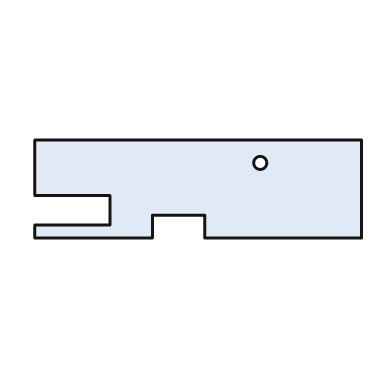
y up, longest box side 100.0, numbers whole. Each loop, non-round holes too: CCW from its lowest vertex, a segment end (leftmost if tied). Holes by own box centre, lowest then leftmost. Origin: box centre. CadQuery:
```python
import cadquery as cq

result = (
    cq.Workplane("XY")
    .moveTo(-50.0, -15.0)
    .lineTo(-14.0, -15.0)
    .lineTo(-14.0, -8.0)
    .lineTo(2.0, -8.0)
    .lineTo(2.0, -15.0)
    .lineTo(50.0, -15.0)
    .lineTo(50.0, 15.0)
    .lineTo(-50.0, 15.0)
    .lineTo(-50.0, -2.0)
    .lineTo(-27.0, -2.0)
    .lineTo(-27.0, -11.0)
    .lineTo(-50.0, -11.0)
    .close()
    .moveTo(19.0, 8.0)
    .circle(2.0)
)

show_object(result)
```